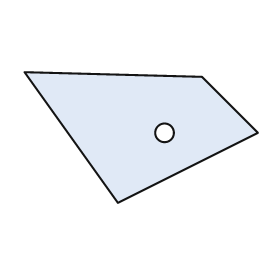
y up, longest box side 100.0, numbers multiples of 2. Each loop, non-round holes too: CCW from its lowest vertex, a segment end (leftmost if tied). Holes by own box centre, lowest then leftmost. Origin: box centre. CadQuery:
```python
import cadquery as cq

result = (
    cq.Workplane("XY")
    .moveTo(-10.0, -28.0)
    .lineTo(50.0, 2.0)
    .lineTo(26.0, 26.0)
    .lineTo(-50.0, 28.0)
    .close()
    .moveTo(10.0, 2.0)
    .circle(4.0)
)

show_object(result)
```